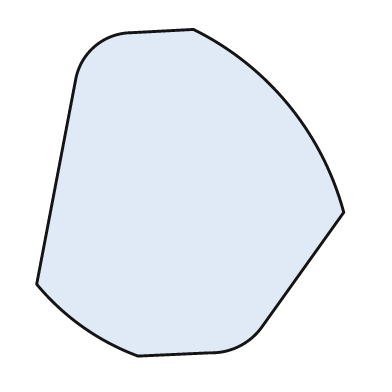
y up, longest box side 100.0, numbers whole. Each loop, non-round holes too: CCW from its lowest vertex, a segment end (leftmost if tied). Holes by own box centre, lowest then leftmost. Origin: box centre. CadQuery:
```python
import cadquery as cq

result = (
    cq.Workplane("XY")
    .moveTo(-16.0, -50.0)
    .lineTo(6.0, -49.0)
    .threePointArc((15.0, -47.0), (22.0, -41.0))
    .lineTo(47.0, -6.0)
    .threePointArc((30.0, 27.0), (1.0, 50.0))
    .lineTo(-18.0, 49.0)
    .threePointArc((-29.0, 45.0), (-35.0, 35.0))
    .lineTo(-47.0, -28.0)
    .threePointArc((-33.0, -41.0), (-16.0, -50.0))
    .close()
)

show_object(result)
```